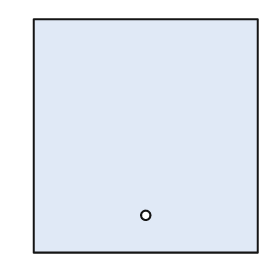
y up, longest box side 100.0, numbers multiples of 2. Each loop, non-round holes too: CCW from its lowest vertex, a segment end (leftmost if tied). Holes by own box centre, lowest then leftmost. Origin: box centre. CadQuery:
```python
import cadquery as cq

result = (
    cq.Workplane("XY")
    .moveTo(-48.0, -50.0)
    .lineTo(48.0, -50.0)
    .lineTo(48.0, 50.0)
    .lineTo(-48.0, 50.0)
    .close()
    .moveTo(0.0, -34.0)
    .circle(2.0)
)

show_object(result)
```